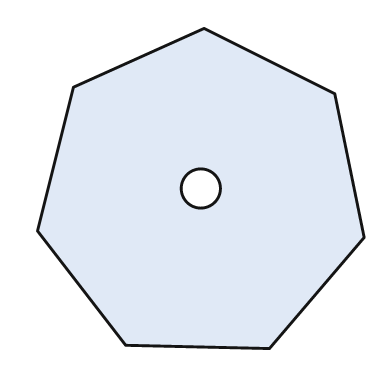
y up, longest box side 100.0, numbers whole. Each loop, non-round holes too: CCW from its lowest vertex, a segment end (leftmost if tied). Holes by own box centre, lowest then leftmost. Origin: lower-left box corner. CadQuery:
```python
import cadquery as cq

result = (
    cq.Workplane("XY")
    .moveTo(71.0, 0.0)
    .lineTo(100.0, 34.0)
    .lineTo(91.0, 78.0)
    .lineTo(51.0, 98.0)
    .lineTo(11.0, 80.0)
    .lineTo(0.0, 36.0)
    .lineTo(27.0, 1.0)
    .close()
    .moveTo(50.0, 49.0)
    .circle(6.0)
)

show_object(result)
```